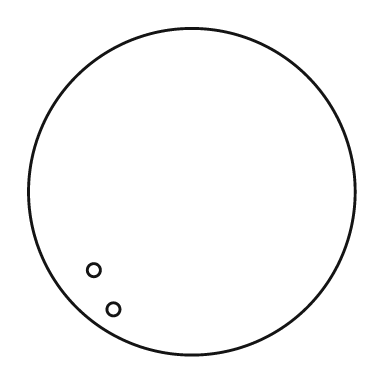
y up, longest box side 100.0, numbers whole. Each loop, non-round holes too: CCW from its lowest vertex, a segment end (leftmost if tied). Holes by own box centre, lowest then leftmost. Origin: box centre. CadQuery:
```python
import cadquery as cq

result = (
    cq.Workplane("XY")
    .moveTo(0.0, 0.0)
    .circle(50.0)
    .moveTo(-24.0, -36.0)
    .circle(2.0)
    .moveTo(-30.0, -24.0)
    .circle(2.0)
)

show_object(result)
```